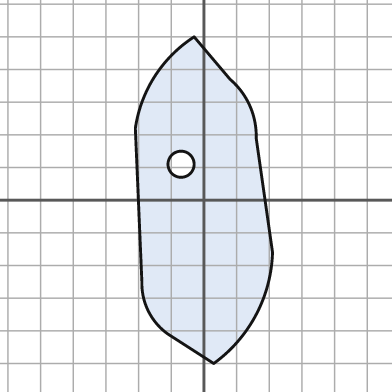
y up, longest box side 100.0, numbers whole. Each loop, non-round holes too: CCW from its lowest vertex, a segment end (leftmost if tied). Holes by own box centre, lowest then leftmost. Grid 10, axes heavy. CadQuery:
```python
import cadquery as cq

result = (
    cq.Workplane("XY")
    .moveTo(3.0, -50.0)
    .threePointArc((16.0, -35.0), (21.0, -16.0))
    .lineTo(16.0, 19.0)
    .threePointArc((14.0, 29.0), (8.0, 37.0))
    .lineTo(-3.0, 50.0)
    .threePointArc((-15.0, 38.0), (-21.0, 22.0))
    .lineTo(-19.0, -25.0)
    .threePointArc((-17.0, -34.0), (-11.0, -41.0))
    .close()
    .moveTo(-7.0, 11.0)
    .circle(4.0)
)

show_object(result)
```